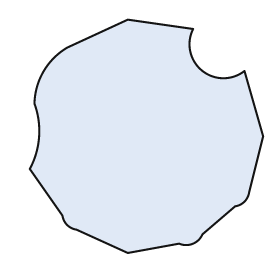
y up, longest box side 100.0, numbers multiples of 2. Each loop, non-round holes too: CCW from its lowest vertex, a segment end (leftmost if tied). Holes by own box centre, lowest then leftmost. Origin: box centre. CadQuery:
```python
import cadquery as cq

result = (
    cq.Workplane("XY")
    .moveTo(-8.0, -50.0)
    .lineTo(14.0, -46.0)
    .threePointArc((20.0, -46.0), (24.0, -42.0))
    .lineTo(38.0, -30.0)
    .threePointArc((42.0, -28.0), (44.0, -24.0))
    .lineTo(50.0, 0.0)
    .lineTo(42.0, 28.0)
    .threePointArc((24.0, 28.0), (20.0, 46.0))
    .lineTo(-8.0, 50.0)
    .lineTo(-34.0, 38.0)
    .threePointArc((-44.0, 28.0), (-48.0, 14.0))
    .threePointArc((-46.0, 0.0), (-50.0, -14.0))
    .lineTo(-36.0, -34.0)
    .threePointArc((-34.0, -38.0), (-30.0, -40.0))
    .close()
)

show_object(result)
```